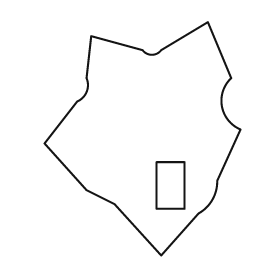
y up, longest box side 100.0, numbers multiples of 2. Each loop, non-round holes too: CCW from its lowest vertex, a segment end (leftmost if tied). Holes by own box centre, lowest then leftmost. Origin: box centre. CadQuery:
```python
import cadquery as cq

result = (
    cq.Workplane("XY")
    .moveTo(8.0, -50.0)
    .lineTo(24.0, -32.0)
    .threePointArc((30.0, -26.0), (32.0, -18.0))
    .lineTo(42.0, 4.0)
    .threePointArc((34.0, 14.0), (38.0, 26.0))
    .lineTo(28.0, 50.0)
    .lineTo(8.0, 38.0)
    .threePointArc((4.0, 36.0), (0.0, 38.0))
    .lineTo(-22.0, 44.0)
    .lineTo(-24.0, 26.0)
    .threePointArc((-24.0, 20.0), (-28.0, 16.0))
    .lineTo(-42.0, -2.0)
    .lineTo(-24.0, -22.0)
    .lineTo(-12.0, -28.0)
    .close()
    .moveTo(6.0, -30.0)
    .lineTo(18.0, -30.0)
    .lineTo(18.0, -10.0)
    .lineTo(6.0, -10.0)
    .close()
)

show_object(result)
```